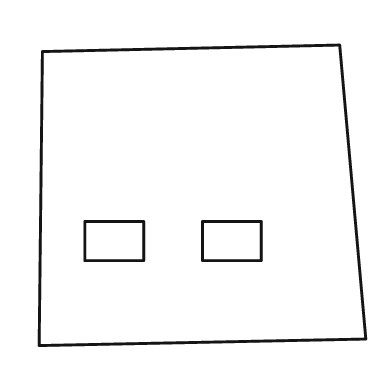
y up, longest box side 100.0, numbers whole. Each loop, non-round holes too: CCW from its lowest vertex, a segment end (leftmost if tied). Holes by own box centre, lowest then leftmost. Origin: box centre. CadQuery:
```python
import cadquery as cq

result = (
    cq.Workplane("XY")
    .moveTo(-50.0, -46.0)
    .lineTo(50.0, -44.0)
    .lineTo(42.0, 46.0)
    .lineTo(-49.0, 44.0)
    .close()
    .moveTo(-36.0, -20.0)
    .lineTo(-18.0, -20.0)
    .lineTo(-18.0, -8.0)
    .lineTo(-36.0, -8.0)
    .close()
    .moveTo(0.0, -20.0)
    .lineTo(18.0, -20.0)
    .lineTo(18.0, -8.0)
    .lineTo(0.0, -8.0)
    .close()
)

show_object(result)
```